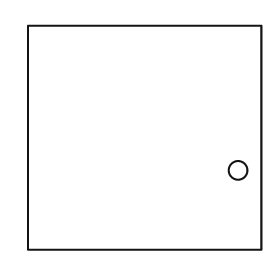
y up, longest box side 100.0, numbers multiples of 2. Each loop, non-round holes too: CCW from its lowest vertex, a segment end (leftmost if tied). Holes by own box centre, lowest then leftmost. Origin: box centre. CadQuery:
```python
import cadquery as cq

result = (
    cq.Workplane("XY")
    .moveTo(-50.0, -48.0)
    .lineTo(50.0, -48.0)
    .lineTo(50.0, 48.0)
    .lineTo(-50.0, 48.0)
    .close()
    .moveTo(40.0, -14.0)
    .circle(4.0)
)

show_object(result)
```